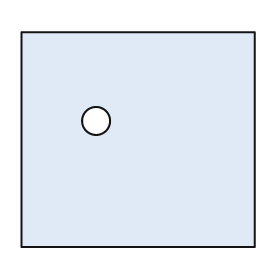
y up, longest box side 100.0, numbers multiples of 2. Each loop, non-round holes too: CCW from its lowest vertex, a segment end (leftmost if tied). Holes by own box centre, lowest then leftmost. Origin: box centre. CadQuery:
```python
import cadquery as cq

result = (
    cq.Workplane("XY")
    .moveTo(-50.0, -46.0)
    .lineTo(50.0, -46.0)
    .lineTo(50.0, 46.0)
    .lineTo(-50.0, 46.0)
    .close()
    .moveTo(-18.0, 8.0)
    .circle(6.0)
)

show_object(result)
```